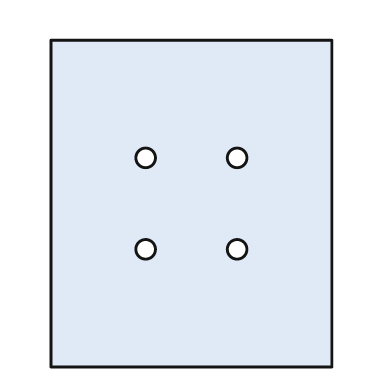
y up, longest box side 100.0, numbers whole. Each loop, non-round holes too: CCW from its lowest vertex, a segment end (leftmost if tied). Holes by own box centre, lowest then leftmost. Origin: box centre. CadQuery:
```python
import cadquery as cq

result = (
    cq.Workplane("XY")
    .moveTo(-43.0, -50.0)
    .lineTo(43.0, -50.0)
    .lineTo(43.0, 50.0)
    .lineTo(-43.0, 50.0)
    .close()
    .moveTo(-14.0, -14.0)
    .circle(3.0)
    .moveTo(14.0, -14.0)
    .circle(3.0)
    .moveTo(-14.0, 14.0)
    .circle(3.0)
    .moveTo(14.0, 14.0)
    .circle(3.0)
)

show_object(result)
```